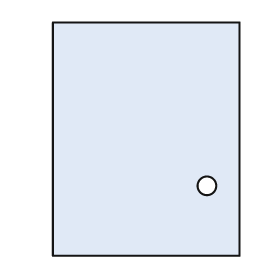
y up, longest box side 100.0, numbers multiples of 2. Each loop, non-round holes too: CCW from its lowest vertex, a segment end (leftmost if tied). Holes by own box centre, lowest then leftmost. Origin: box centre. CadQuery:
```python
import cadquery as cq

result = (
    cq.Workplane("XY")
    .moveTo(-40.0, -50.0)
    .lineTo(40.0, -50.0)
    .lineTo(40.0, 50.0)
    .lineTo(-40.0, 50.0)
    .close()
    .moveTo(26.0, -20.0)
    .circle(4.0)
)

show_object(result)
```